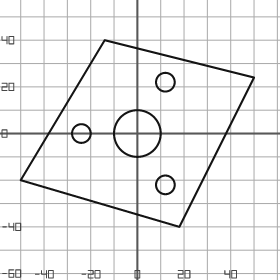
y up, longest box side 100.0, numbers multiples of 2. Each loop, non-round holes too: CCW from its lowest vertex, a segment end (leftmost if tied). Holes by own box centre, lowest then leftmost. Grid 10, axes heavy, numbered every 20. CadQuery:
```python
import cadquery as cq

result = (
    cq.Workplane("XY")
    .moveTo(18.0, -40.0)
    .lineTo(50.0, 24.0)
    .lineTo(-14.0, 40.0)
    .lineTo(-50.0, -20.0)
    .close()
    .moveTo(12.0, -22.0)
    .circle(4.0)
    .moveTo(-24.0, 0.0)
    .circle(4.0)
    .moveTo(0.0, 0.0)
    .circle(10.0)
    .moveTo(12.0, 22.0)
    .circle(4.0)
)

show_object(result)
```